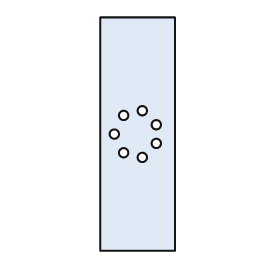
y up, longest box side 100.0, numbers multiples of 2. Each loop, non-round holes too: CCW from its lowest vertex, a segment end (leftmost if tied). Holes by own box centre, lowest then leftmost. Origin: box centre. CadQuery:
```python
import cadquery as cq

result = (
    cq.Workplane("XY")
    .moveTo(-16.0, -50.0)
    .lineTo(16.0, -50.0)
    .lineTo(16.0, 50.0)
    .lineTo(-16.0, 50.0)
    .close()
    .moveTo(2.0, -10.0)
    .circle(2.0)
    .moveTo(-6.0, -8.0)
    .circle(2.0)
    .moveTo(8.0, -4.0)
    .circle(2.0)
    .moveTo(-10.0, 0.0)
    .circle(2.0)
    .moveTo(8.0, 4.0)
    .circle(2.0)
    .moveTo(-6.0, 8.0)
    .circle(2.0)
    .moveTo(2.0, 10.0)
    .circle(2.0)
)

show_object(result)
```